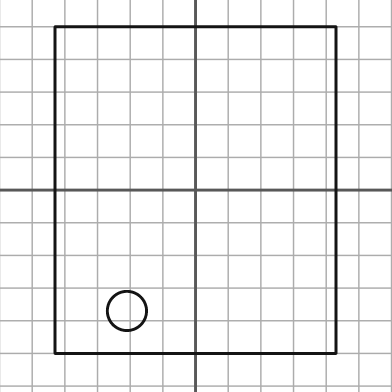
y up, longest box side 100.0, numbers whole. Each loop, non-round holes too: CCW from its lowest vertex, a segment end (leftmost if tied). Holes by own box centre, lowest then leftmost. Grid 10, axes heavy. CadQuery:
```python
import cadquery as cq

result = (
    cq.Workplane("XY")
    .moveTo(-43.0, -50.0)
    .lineTo(43.0, -50.0)
    .lineTo(43.0, 50.0)
    .lineTo(-43.0, 50.0)
    .close()
    .moveTo(-21.0, -37.0)
    .circle(6.0)
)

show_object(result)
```